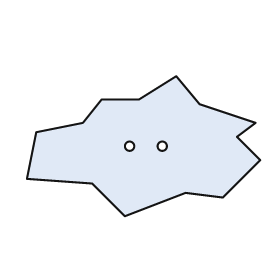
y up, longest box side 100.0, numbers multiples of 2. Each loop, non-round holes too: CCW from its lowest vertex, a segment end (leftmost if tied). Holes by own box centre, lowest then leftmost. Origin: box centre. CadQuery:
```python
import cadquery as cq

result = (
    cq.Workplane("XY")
    .moveTo(-8.0, -30.0)
    .lineTo(18.0, -20.0)
    .lineTo(34.0, -22.0)
    .lineTo(50.0, -6.0)
    .lineTo(40.0, 4.0)
    .lineTo(48.0, 10.0)
    .lineTo(24.0, 18.0)
    .lineTo(14.0, 30.0)
    .lineTo(-2.0, 20.0)
    .lineTo(-18.0, 20.0)
    .lineTo(-26.0, 10.0)
    .lineTo(-46.0, 6.0)
    .lineTo(-50.0, -14.0)
    .lineTo(-22.0, -16.0)
    .close()
    .moveTo(-6.0, 0.0)
    .circle(2.0)
    .moveTo(8.0, 0.0)
    .circle(2.0)
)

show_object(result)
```